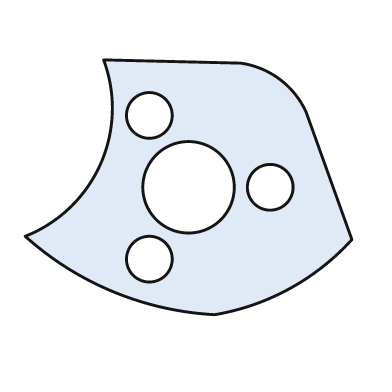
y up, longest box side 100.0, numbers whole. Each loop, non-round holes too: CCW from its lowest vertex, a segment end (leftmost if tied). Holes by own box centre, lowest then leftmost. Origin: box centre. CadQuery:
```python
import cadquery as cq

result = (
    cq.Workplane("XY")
    .moveTo(8.0, -39.0)
    .threePointArc((31.0, -31.0), (50.0, -16.0))
    .lineTo(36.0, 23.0)
    .threePointArc((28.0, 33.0), (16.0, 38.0))
    .lineTo(-26.0, 39.0)
    .threePointArc((-27.0, 7.0), (-50.0, -15.0))
    .threePointArc((-23.0, -32.0), (8.0, -39.0))
    .close()
    .moveTo(-12.0, -22.0)
    .circle(7.0)
    .moveTo(0.0, 0.0)
    .circle(14.0)
    .moveTo(25.0, 0.0)
    .circle(7.0)
    .moveTo(-12.0, 22.0)
    .circle(7.0)
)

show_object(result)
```